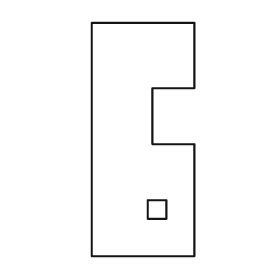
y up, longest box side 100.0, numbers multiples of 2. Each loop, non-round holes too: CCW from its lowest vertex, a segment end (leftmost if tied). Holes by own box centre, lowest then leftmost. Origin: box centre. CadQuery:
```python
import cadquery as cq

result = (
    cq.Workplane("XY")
    .moveTo(-22.0, -50.0)
    .lineTo(22.0, -50.0)
    .lineTo(22.0, -2.0)
    .lineTo(4.0, -2.0)
    .lineTo(4.0, 22.0)
    .lineTo(22.0, 22.0)
    .lineTo(22.0, 50.0)
    .lineTo(-22.0, 50.0)
    .close()
    .moveTo(2.0, -34.0)
    .lineTo(10.0, -34.0)
    .lineTo(10.0, -26.0)
    .lineTo(2.0, -26.0)
    .close()
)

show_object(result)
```